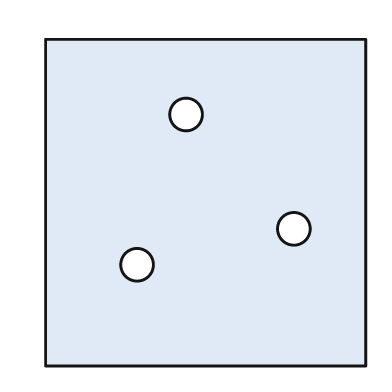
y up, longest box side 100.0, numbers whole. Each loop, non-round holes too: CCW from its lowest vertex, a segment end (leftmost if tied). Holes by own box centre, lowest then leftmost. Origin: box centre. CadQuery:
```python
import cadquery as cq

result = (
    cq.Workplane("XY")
    .moveTo(-49.0, -50.0)
    .lineTo(49.0, -50.0)
    .lineTo(49.0, 50.0)
    .lineTo(-49.0, 50.0)
    .close()
    .moveTo(-21.0, -19.0)
    .circle(5.0)
    .moveTo(27.0, -8.0)
    .circle(5.0)
    .moveTo(-6.0, 27.0)
    .circle(5.0)
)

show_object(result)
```